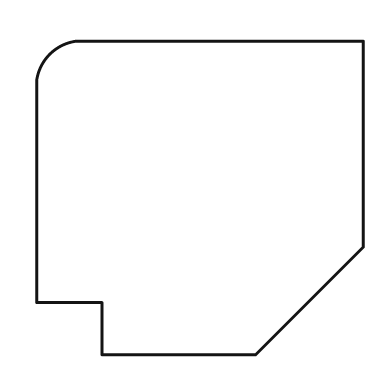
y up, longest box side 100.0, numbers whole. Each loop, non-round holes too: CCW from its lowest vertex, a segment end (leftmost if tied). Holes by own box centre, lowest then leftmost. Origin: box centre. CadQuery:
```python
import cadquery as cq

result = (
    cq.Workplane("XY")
    .moveTo(-30.0, -48.0)
    .lineTo(17.0, -48.0)
    .lineTo(50.0, -15.0)
    .lineTo(50.0, 48.0)
    .lineTo(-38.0, 48.0)
    .threePointArc((-46.0, 44.0), (-50.0, 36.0))
    .lineTo(-50.0, -32.0)
    .lineTo(-30.0, -32.0)
    .close()
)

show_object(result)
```